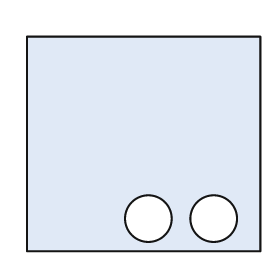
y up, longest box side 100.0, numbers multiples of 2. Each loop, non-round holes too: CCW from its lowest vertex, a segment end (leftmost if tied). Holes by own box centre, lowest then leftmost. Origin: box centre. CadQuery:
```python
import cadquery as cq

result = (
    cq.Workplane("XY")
    .moveTo(-50.0, -46.0)
    .lineTo(50.0, -46.0)
    .lineTo(50.0, 46.0)
    .lineTo(-50.0, 46.0)
    .close()
    .moveTo(2.0, -32.0)
    .circle(10.0)
    .moveTo(30.0, -32.0)
    .circle(10.0)
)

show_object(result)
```